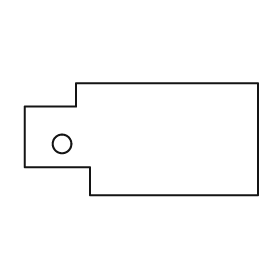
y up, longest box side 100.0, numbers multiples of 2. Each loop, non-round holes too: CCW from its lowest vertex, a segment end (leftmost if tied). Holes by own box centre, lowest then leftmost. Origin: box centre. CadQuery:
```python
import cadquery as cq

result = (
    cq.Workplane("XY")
    .moveTo(-22.0, -24.0)
    .lineTo(50.0, -24.0)
    .lineTo(50.0, 24.0)
    .lineTo(-28.0, 24.0)
    .lineTo(-28.0, 14.0)
    .lineTo(-50.0, 14.0)
    .lineTo(-50.0, -12.0)
    .lineTo(-22.0, -12.0)
    .close()
    .moveTo(-34.0, -2.0)
    .circle(4.0)
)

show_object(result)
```